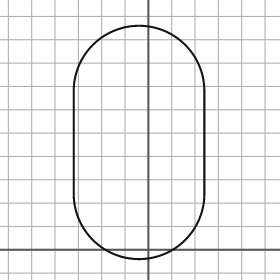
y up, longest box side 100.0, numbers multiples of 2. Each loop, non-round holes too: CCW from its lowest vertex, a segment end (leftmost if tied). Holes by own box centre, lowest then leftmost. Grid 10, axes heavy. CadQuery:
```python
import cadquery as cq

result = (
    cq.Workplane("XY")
    .moveTo(-32.0, 24.0)
    .threePointArc((-4.0, -4.0), (24.0, 24.0))
    .lineTo(24.0, 68.0)
    .threePointArc((-4.0, 96.0), (-32.0, 68.0))
    .close()
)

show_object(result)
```